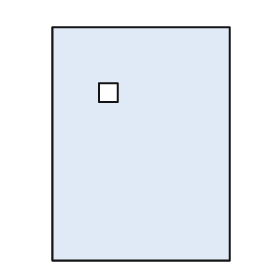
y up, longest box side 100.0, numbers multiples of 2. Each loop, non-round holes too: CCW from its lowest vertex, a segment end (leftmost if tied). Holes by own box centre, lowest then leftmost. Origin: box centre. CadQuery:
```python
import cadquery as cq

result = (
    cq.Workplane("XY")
    .moveTo(-38.0, -50.0)
    .lineTo(38.0, -50.0)
    .lineTo(38.0, 50.0)
    .lineTo(-38.0, 50.0)
    .close()
    .moveTo(-18.0, 18.0)
    .lineTo(-10.0, 18.0)
    .lineTo(-10.0, 26.0)
    .lineTo(-18.0, 26.0)
    .close()
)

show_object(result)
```